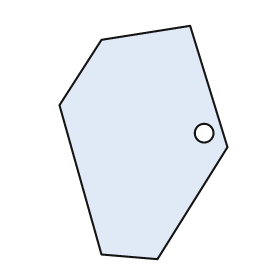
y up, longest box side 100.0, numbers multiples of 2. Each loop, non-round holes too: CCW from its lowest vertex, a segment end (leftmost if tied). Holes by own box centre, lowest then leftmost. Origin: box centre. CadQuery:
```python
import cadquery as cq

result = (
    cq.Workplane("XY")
    .moveTo(6.0, -50.0)
    .lineTo(36.0, -2.0)
    .lineTo(20.0, 50.0)
    .lineTo(-18.0, 44.0)
    .lineTo(-36.0, 16.0)
    .lineTo(-18.0, -48.0)
    .close()
    .moveTo(26.0, 4.0)
    .circle(4.0)
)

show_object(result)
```